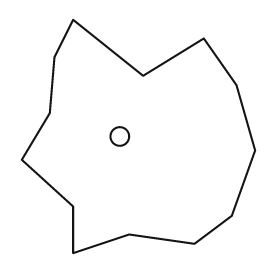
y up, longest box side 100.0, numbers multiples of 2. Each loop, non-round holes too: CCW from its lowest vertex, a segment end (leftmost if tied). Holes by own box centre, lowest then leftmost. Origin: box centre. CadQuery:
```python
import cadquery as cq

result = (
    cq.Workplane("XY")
    .moveTo(-28.0, -50.0)
    .lineTo(-4.0, -42.0)
    .lineTo(24.0, -46.0)
    .lineTo(40.0, -34.0)
    .lineTo(50.0, -6.0)
    .lineTo(42.0, 22.0)
    .lineTo(28.0, 42.0)
    .lineTo(2.0, 26.0)
    .lineTo(-28.0, 50.0)
    .lineTo(-36.0, 34.0)
    .lineTo(-38.0, 10.0)
    .lineTo(-50.0, -10.0)
    .lineTo(-28.0, -30.0)
    .close()
    .moveTo(-8.0, 0.0)
    .circle(4.0)
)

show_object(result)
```